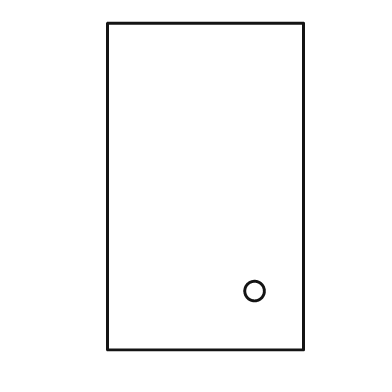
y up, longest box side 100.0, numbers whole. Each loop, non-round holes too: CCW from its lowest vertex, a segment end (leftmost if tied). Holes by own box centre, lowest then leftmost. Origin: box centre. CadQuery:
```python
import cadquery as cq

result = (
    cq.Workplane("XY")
    .moveTo(-30.0, -50.0)
    .lineTo(30.0, -50.0)
    .lineTo(30.0, 50.0)
    .lineTo(-30.0, 50.0)
    .close()
    .moveTo(15.0, -32.0)
    .circle(3.0)
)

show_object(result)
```